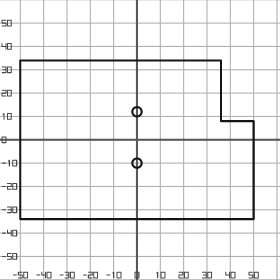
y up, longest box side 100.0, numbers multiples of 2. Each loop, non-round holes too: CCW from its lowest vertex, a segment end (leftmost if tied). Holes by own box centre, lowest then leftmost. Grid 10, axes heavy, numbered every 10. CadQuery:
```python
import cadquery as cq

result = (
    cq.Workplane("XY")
    .moveTo(-50.0, -34.0)
    .lineTo(50.0, -34.0)
    .lineTo(50.0, 8.0)
    .lineTo(36.0, 8.0)
    .lineTo(36.0, 34.0)
    .lineTo(-50.0, 34.0)
    .close()
    .moveTo(0.0, -10.0)
    .circle(2.0)
    .moveTo(0.0, 12.0)
    .circle(2.0)
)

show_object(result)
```